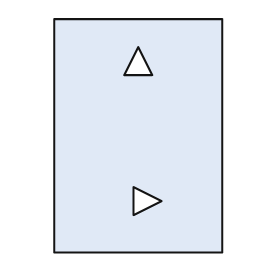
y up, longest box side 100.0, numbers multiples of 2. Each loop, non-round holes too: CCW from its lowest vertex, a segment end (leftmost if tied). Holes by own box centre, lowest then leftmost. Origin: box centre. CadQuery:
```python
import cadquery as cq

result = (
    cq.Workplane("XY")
    .moveTo(-36.0, -50.0)
    .lineTo(36.0, -50.0)
    .lineTo(36.0, 50.0)
    .lineTo(-36.0, 50.0)
    .close()
    .moveTo(-2.0, -34.0)
    .lineTo(10.0, -28.0)
    .lineTo(-2.0, -22.0)
    .close()
    .moveTo(-6.0, 26.0)
    .lineTo(6.0, 26.0)
    .lineTo(0.0, 38.0)
    .close()
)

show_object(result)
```